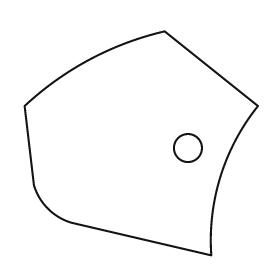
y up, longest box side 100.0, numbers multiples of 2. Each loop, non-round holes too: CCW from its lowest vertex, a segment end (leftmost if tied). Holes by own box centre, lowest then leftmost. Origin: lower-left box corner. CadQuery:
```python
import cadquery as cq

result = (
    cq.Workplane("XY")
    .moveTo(80.0, 0.0)
    .threePointArc((84.0, 34.0), (100.0, 64.0))
    .lineTo(60.0, 96.0)
    .threePointArc((28.0, 84.0), (0.0, 64.0))
    .lineTo(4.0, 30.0)
    .threePointArc((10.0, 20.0), (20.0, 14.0))
    .close()
    .moveTo(70.0, 46.0)
    .circle(6.0)
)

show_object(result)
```